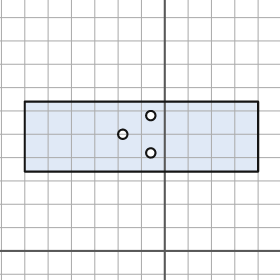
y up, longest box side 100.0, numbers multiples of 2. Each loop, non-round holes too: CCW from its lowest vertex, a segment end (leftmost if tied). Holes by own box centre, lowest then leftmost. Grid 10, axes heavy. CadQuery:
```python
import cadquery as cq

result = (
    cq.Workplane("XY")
    .moveTo(-60.0, 34.0)
    .lineTo(40.0, 34.0)
    .lineTo(40.0, 64.0)
    .lineTo(-60.0, 64.0)
    .close()
    .moveTo(-6.0, 42.0)
    .circle(2.0)
    .moveTo(-18.0, 50.0)
    .circle(2.0)
    .moveTo(-6.0, 58.0)
    .circle(2.0)
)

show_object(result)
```